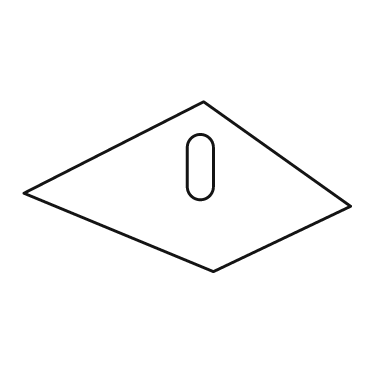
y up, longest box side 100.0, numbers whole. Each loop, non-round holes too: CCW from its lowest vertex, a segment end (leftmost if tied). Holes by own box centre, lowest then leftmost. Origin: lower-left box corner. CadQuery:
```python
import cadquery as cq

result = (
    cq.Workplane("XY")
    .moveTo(58.0, 0.0)
    .lineTo(100.0, 20.0)
    .lineTo(55.0, 52.0)
    .lineTo(0.0, 24.0)
    .close()
    .moveTo(50.0, 26.0)
    .threePointArc((54.0, 22.0), (58.0, 26.0))
    .lineTo(58.0, 38.0)
    .threePointArc((54.0, 42.0), (50.0, 38.0))
    .close()
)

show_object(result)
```